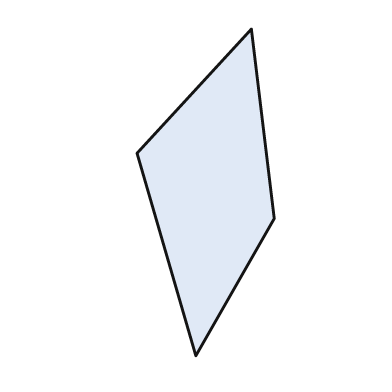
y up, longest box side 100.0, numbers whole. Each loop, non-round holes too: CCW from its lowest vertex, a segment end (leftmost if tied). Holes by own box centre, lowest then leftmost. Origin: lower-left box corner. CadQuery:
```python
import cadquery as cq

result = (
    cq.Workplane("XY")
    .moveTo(18.0, 0.0)
    .lineTo(42.0, 42.0)
    .lineTo(35.0, 100.0)
    .lineTo(0.0, 62.0)
    .close()
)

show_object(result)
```